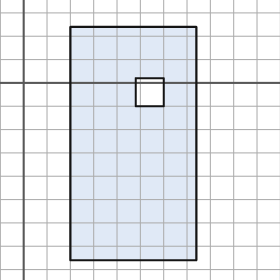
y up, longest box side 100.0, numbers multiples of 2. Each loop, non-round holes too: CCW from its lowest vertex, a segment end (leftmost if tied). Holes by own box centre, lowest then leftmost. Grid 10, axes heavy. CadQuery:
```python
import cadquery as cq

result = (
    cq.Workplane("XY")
    .moveTo(20.0, -76.0)
    .lineTo(74.0, -76.0)
    .lineTo(74.0, 24.0)
    .lineTo(20.0, 24.0)
    .close()
    .moveTo(48.0, -10.0)
    .lineTo(60.0, -10.0)
    .lineTo(60.0, 2.0)
    .lineTo(48.0, 2.0)
    .close()
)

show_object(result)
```